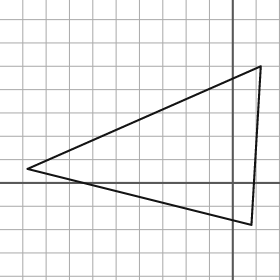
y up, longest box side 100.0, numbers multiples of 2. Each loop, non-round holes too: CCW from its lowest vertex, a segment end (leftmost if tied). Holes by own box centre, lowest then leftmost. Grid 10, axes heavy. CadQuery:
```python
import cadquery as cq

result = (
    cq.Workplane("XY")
    .moveTo(8.0, -18.0)
    .lineTo(12.0, 50.0)
    .lineTo(-88.0, 6.0)
    .close()
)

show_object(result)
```